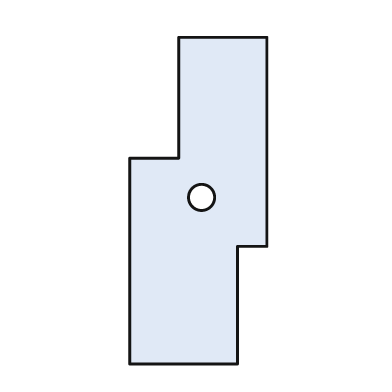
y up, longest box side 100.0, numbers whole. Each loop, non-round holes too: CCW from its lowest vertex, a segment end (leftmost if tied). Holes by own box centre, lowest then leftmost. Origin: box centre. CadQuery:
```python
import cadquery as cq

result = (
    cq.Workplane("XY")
    .moveTo(-21.0, -50.0)
    .lineTo(12.0, -50.0)
    .lineTo(12.0, -14.0)
    .lineTo(21.0, -14.0)
    .lineTo(21.0, 50.0)
    .lineTo(-6.0, 50.0)
    .lineTo(-6.0, 13.0)
    .lineTo(-21.0, 13.0)
    .close()
    .moveTo(1.0, 1.0)
    .circle(4.0)
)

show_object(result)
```